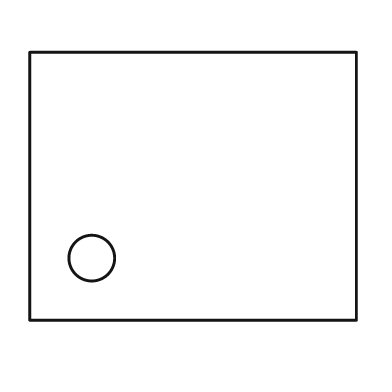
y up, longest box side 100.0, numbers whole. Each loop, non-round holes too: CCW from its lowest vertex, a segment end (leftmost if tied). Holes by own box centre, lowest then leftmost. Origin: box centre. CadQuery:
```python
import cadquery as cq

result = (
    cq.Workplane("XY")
    .moveTo(-50.0, -41.0)
    .lineTo(50.0, -41.0)
    .lineTo(50.0, 41.0)
    .lineTo(-50.0, 41.0)
    .close()
    .moveTo(-31.0, -22.0)
    .circle(7.0)
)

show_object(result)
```